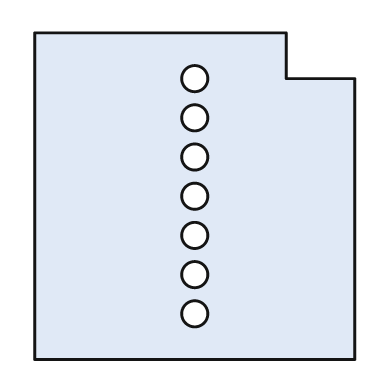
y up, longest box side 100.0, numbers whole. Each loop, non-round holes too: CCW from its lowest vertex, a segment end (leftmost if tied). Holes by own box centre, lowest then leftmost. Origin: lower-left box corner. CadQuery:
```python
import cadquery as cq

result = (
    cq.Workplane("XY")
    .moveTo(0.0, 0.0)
    .lineTo(98.0, 0.0)
    .lineTo(98.0, 86.0)
    .lineTo(77.0, 86.0)
    .lineTo(77.0, 100.0)
    .lineTo(0.0, 100.0)
    .close()
    .moveTo(49.0, 14.0)
    .circle(4.0)
    .moveTo(49.0, 26.0)
    .circle(4.0)
    .moveTo(49.0, 38.0)
    .circle(4.0)
    .moveTo(49.0, 50.0)
    .circle(4.0)
    .moveTo(49.0, 62.0)
    .circle(4.0)
    .moveTo(49.0, 74.0)
    .circle(4.0)
    .moveTo(49.0, 86.0)
    .circle(4.0)
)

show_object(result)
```